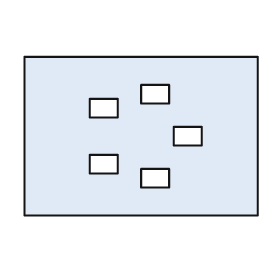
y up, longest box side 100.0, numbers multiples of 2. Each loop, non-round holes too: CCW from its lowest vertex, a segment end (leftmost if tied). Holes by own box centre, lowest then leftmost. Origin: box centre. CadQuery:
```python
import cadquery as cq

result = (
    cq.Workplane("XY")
    .moveTo(-50.0, -34.0)
    .lineTo(50.0, -34.0)
    .lineTo(50.0, 34.0)
    .lineTo(-50.0, 34.0)
    .close()
    .moveTo(0.0, -22.0)
    .lineTo(12.0, -22.0)
    .lineTo(12.0, -14.0)
    .lineTo(0.0, -14.0)
    .close()
    .moveTo(-22.0, -16.0)
    .lineTo(-10.0, -16.0)
    .lineTo(-10.0, -8.0)
    .lineTo(-22.0, -8.0)
    .close()
    .moveTo(14.0, -4.0)
    .lineTo(26.0, -4.0)
    .lineTo(26.0, 4.0)
    .lineTo(14.0, 4.0)
    .close()
    .moveTo(-22.0, 8.0)
    .lineTo(-10.0, 8.0)
    .lineTo(-10.0, 16.0)
    .lineTo(-22.0, 16.0)
    .close()
    .moveTo(0.0, 14.0)
    .lineTo(12.0, 14.0)
    .lineTo(12.0, 22.0)
    .lineTo(0.0, 22.0)
    .close()
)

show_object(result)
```